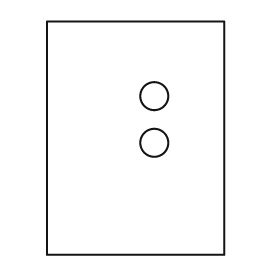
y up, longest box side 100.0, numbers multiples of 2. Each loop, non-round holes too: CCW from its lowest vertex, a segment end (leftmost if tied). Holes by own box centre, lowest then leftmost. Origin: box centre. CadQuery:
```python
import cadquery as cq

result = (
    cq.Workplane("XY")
    .moveTo(-38.0, -50.0)
    .lineTo(38.0, -50.0)
    .lineTo(38.0, 50.0)
    .lineTo(-38.0, 50.0)
    .close()
    .moveTo(8.0, -2.0)
    .circle(6.0)
    .moveTo(8.0, 18.0)
    .circle(6.0)
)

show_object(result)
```